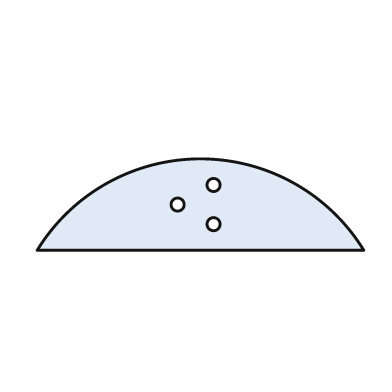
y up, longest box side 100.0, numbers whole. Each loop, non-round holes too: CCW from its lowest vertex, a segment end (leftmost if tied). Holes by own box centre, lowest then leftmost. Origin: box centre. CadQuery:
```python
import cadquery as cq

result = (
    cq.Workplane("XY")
    .moveTo(-50.0, -14.0)
    .lineTo(50.0, -14.0)
    .threePointArc((0.0, 14.0), (-50.0, -14.0))
    .close()
    .moveTo(4.0, -6.0)
    .circle(2.0)
    .moveTo(-7.0, 0.0)
    .circle(2.0)
    .moveTo(4.0, 6.0)
    .circle(2.0)
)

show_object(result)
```